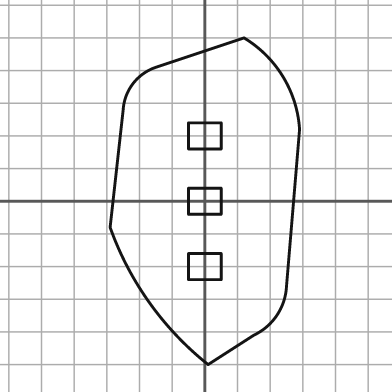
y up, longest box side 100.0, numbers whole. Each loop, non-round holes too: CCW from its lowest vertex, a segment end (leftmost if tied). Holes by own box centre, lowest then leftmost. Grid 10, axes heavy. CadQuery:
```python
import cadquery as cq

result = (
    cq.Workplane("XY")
    .moveTo(1.0, -50.0)
    .lineTo(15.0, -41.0)
    .threePointArc((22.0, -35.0), (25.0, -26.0))
    .lineTo(29.0, 22.0)
    .threePointArc((24.0, 38.0), (12.0, 50.0))
    .lineTo(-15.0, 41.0)
    .threePointArc((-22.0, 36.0), (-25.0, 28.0))
    .lineTo(-29.0, -8.0)
    .threePointArc((-17.0, -31.0), (1.0, -50.0))
    .close()
    .moveTo(-5.0, -24.0)
    .lineTo(5.0, -24.0)
    .lineTo(5.0, -16.0)
    .lineTo(-5.0, -16.0)
    .close()
    .moveTo(-5.0, -4.0)
    .lineTo(5.0, -4.0)
    .lineTo(5.0, 4.0)
    .lineTo(-5.0, 4.0)
    .close()
    .moveTo(-5.0, 16.0)
    .lineTo(5.0, 16.0)
    .lineTo(5.0, 24.0)
    .lineTo(-5.0, 24.0)
    .close()
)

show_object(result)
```